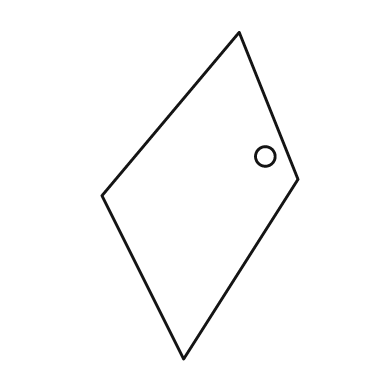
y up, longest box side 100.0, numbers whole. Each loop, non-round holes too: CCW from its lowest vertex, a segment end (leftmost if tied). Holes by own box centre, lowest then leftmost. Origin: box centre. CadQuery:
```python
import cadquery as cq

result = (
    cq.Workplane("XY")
    .moveTo(-5.0, -50.0)
    .lineTo(30.0, 5.0)
    .lineTo(12.0, 50.0)
    .lineTo(-30.0, 0.0)
    .close()
    .moveTo(20.0, 12.0)
    .circle(3.0)
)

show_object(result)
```